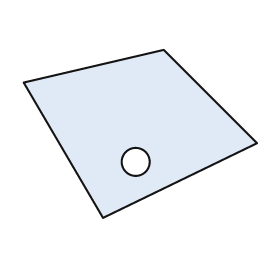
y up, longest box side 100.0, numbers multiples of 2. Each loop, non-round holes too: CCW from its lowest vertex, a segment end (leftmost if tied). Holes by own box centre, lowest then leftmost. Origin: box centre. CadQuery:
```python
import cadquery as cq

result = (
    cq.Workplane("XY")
    .moveTo(-16.0, -36.0)
    .lineTo(50.0, -4.0)
    .lineTo(10.0, 36.0)
    .lineTo(-50.0, 22.0)
    .close()
    .moveTo(-2.0, -12.0)
    .circle(6.0)
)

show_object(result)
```